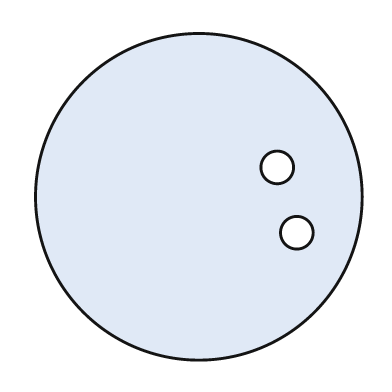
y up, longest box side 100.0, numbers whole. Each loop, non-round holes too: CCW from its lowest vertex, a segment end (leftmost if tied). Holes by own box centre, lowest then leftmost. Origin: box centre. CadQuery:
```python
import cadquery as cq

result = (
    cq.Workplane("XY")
    .moveTo(0.0, 0.0)
    .circle(50.0)
    .moveTo(30.0, -11.0)
    .circle(5.0)
    .moveTo(24.0, 9.0)
    .circle(5.0)
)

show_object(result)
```